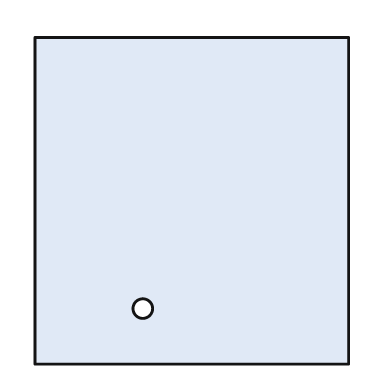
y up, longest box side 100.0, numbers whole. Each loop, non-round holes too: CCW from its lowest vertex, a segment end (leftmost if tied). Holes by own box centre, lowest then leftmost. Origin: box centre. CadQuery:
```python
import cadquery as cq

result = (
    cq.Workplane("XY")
    .moveTo(-48.0, -50.0)
    .lineTo(48.0, -50.0)
    .lineTo(48.0, 50.0)
    .lineTo(-48.0, 50.0)
    .close()
    .moveTo(-15.0, -33.0)
    .circle(3.0)
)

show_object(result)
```